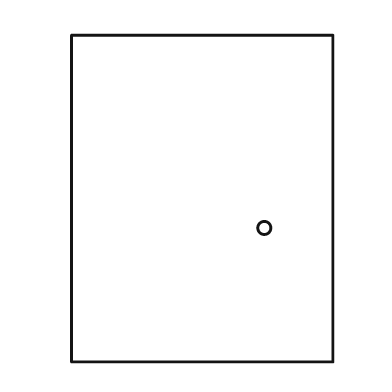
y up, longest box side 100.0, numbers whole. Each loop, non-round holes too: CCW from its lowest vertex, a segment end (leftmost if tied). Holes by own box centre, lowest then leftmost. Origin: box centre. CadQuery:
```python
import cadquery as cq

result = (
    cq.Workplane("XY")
    .moveTo(-40.0, -50.0)
    .lineTo(40.0, -50.0)
    .lineTo(40.0, 50.0)
    .lineTo(-40.0, 50.0)
    .close()
    .moveTo(19.0, -9.0)
    .circle(2.0)
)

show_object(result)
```